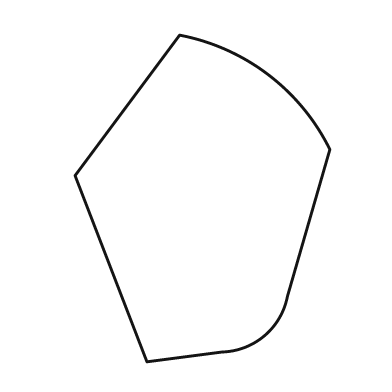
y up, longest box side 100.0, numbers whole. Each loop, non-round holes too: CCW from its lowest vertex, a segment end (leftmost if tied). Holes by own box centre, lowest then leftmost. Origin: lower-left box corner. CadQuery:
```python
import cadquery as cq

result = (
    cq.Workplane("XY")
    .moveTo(22.0, 0.0)
    .lineTo(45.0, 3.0)
    .threePointArc((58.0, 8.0), (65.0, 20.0))
    .lineTo(78.0, 65.0)
    .threePointArc((59.0, 88.0), (32.0, 100.0))
    .lineTo(0.0, 57.0)
    .close()
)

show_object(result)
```